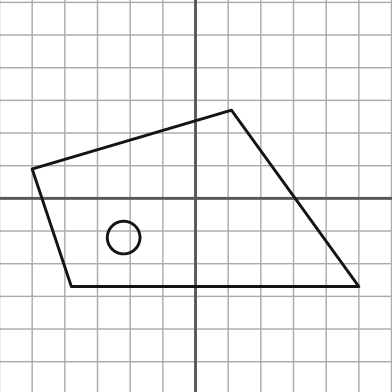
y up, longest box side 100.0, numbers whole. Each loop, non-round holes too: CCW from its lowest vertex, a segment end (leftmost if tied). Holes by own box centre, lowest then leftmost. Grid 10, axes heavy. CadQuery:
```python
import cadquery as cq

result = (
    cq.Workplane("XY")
    .moveTo(-38.0, -27.0)
    .lineTo(50.0, -27.0)
    .lineTo(11.0, 27.0)
    .lineTo(-50.0, 9.0)
    .close()
    .moveTo(-22.0, -12.0)
    .circle(5.0)
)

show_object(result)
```